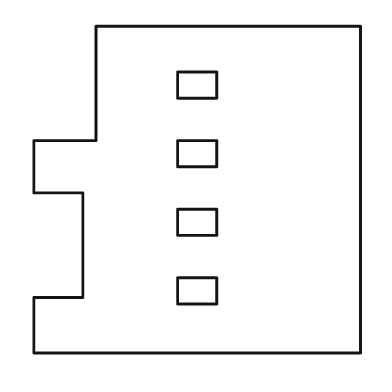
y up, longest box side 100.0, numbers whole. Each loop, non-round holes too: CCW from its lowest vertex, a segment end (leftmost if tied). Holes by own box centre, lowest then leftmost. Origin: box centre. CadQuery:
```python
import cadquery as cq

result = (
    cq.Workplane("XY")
    .moveTo(-50.0, -50.0)
    .lineTo(50.0, -50.0)
    .lineTo(50.0, 50.0)
    .lineTo(-31.0, 50.0)
    .lineTo(-31.0, 15.0)
    .lineTo(-50.0, 15.0)
    .lineTo(-50.0, -1.0)
    .lineTo(-35.0, -1.0)
    .lineTo(-35.0, -33.0)
    .lineTo(-50.0, -33.0)
    .close()
    .moveTo(-6.0, -35.0)
    .lineTo(6.0, -35.0)
    .lineTo(6.0, -27.0)
    .lineTo(-6.0, -27.0)
    .close()
    .moveTo(-6.0, -14.0)
    .lineTo(6.0, -14.0)
    .lineTo(6.0, -6.0)
    .lineTo(-6.0, -6.0)
    .close()
    .moveTo(-6.0, 7.0)
    .lineTo(6.0, 7.0)
    .lineTo(6.0, 15.0)
    .lineTo(-6.0, 15.0)
    .close()
    .moveTo(-6.0, 28.0)
    .lineTo(6.0, 28.0)
    .lineTo(6.0, 36.0)
    .lineTo(-6.0, 36.0)
    .close()
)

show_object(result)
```